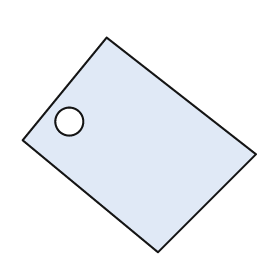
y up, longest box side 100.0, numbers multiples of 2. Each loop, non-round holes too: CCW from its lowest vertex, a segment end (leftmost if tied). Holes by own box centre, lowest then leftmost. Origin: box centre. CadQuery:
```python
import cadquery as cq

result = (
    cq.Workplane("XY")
    .moveTo(8.0, -46.0)
    .lineTo(50.0, -4.0)
    .lineTo(-14.0, 46.0)
    .lineTo(-50.0, 2.0)
    .close()
    .moveTo(-30.0, 10.0)
    .circle(6.0)
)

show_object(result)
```